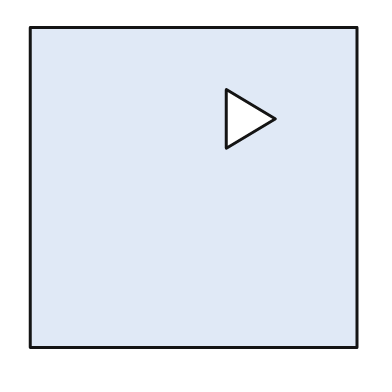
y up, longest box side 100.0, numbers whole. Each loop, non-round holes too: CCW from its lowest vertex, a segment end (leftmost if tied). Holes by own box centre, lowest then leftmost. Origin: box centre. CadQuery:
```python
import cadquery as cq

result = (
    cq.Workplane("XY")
    .moveTo(-50.0, -49.0)
    .lineTo(50.0, -49.0)
    .lineTo(50.0, 49.0)
    .lineTo(-50.0, 49.0)
    .close()
    .moveTo(10.0, 12.0)
    .lineTo(25.0, 21.0)
    .lineTo(10.0, 30.0)
    .close()
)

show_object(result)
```